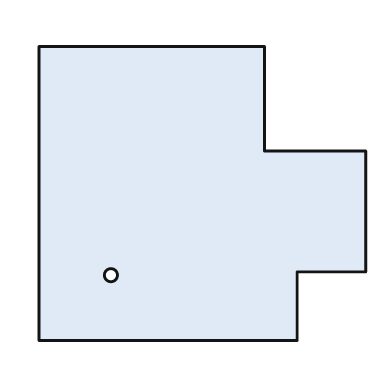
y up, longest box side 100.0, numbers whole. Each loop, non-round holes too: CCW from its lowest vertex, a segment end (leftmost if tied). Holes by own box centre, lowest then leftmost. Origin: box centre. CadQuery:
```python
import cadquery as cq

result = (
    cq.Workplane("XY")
    .moveTo(-50.0, -45.0)
    .lineTo(29.0, -45.0)
    .lineTo(29.0, -24.0)
    .lineTo(50.0, -24.0)
    .lineTo(50.0, 13.0)
    .lineTo(19.0, 13.0)
    .lineTo(19.0, 45.0)
    .lineTo(-50.0, 45.0)
    .close()
    .moveTo(-28.0, -25.0)
    .circle(2.0)
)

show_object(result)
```